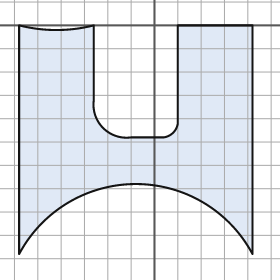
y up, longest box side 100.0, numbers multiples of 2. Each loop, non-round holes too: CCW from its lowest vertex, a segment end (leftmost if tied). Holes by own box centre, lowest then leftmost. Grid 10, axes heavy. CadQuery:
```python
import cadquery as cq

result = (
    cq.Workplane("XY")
    .moveTo(-58.0, -98.0)
    .threePointArc((-8.0, -68.0), (42.0, -98.0))
    .lineTo(42.0, 0.0)
    .lineTo(10.0, 0.0)
    .lineTo(10.0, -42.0)
    .threePointArc((8.0, -46.0), (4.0, -48.0))
    .lineTo(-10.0, -48.0)
    .threePointArc((-22.0, -44.0), (-26.0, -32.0))
    .lineTo(-26.0, 0.0)
    .threePointArc((-42.0, -2.0), (-58.0, 0.0))
    .close()
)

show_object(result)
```